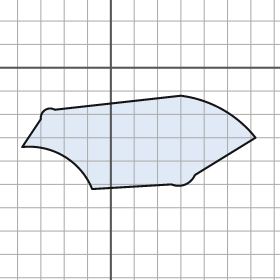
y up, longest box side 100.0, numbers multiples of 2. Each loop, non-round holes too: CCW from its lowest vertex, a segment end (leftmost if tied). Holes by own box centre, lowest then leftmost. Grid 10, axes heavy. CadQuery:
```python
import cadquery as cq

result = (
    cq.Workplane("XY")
    .moveTo(-8.0, -52.0)
    .lineTo(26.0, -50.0)
    .threePointArc((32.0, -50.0), (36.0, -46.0))
    .lineTo(62.0, -30.0)
    .threePointArc((48.0, -18.0), (30.0, -12.0))
    .lineTo(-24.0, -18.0)
    .threePointArc((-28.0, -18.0), (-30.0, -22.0))
    .lineTo(-38.0, -34.0)
    .threePointArc((-20.0, -38.0), (-8.0, -52.0))
    .close()
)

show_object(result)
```